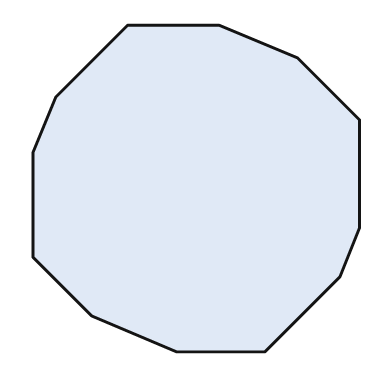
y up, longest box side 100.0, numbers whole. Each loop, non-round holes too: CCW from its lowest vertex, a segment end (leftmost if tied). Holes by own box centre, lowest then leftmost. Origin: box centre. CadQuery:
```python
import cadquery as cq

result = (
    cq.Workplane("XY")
    .moveTo(-6.0, -50.0)
    .lineTo(21.0, -50.0)
    .lineTo(44.0, -27.0)
    .lineTo(50.0, -12.0)
    .lineTo(50.0, 21.0)
    .lineTo(31.0, 40.0)
    .lineTo(7.0, 50.0)
    .lineTo(-21.0, 50.0)
    .lineTo(-43.0, 28.0)
    .lineTo(-50.0, 11.0)
    .lineTo(-50.0, -21.0)
    .lineTo(-32.0, -39.0)
    .close()
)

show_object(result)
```